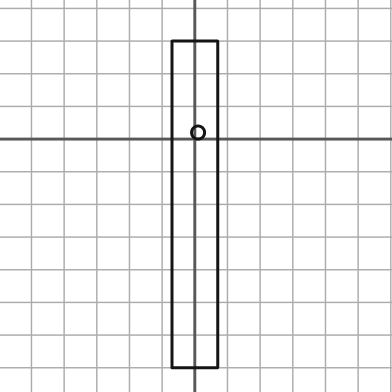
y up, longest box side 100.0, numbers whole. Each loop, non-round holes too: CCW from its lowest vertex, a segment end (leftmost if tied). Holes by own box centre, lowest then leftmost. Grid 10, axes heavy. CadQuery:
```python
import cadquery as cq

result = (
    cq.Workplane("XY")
    .moveTo(-7.0, -70.0)
    .lineTo(7.0, -70.0)
    .lineTo(7.0, 30.0)
    .lineTo(-7.0, 30.0)
    .close()
    .moveTo(1.0, 2.0)
    .circle(2.0)
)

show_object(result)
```